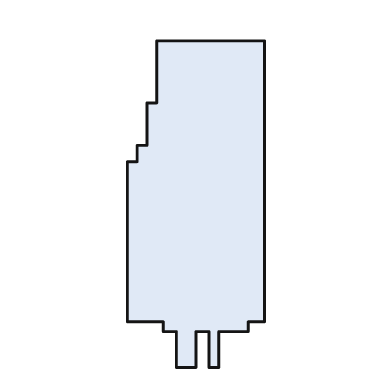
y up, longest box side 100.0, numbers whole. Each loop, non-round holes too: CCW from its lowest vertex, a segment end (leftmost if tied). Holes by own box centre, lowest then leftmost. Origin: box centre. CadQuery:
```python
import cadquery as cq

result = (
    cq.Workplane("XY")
    .moveTo(-6.0, -50.0)
    .lineTo(0.0, -50.0)
    .lineTo(0.0, -39.0)
    .lineTo(4.0, -39.0)
    .lineTo(4.0, -50.0)
    .lineTo(7.0, -50.0)
    .lineTo(7.0, -39.0)
    .lineTo(16.0, -39.0)
    .lineTo(16.0, -36.0)
    .lineTo(21.0, -36.0)
    .lineTo(21.0, 50.0)
    .lineTo(-12.0, 50.0)
    .lineTo(-12.0, 31.0)
    .lineTo(-15.0, 31.0)
    .lineTo(-15.0, 18.0)
    .lineTo(-18.0, 18.0)
    .lineTo(-18.0, 13.0)
    .lineTo(-21.0, 13.0)
    .lineTo(-21.0, -36.0)
    .lineTo(-10.0, -36.0)
    .lineTo(-10.0, -39.0)
    .lineTo(-6.0, -39.0)
    .close()
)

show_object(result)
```